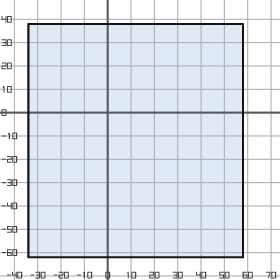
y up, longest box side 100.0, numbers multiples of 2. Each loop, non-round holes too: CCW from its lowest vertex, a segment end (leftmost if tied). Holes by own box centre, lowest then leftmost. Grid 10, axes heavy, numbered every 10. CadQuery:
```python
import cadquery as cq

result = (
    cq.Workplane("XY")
    .moveTo(-34.0, -62.0)
    .lineTo(58.0, -62.0)
    .lineTo(58.0, 38.0)
    .lineTo(-34.0, 38.0)
    .close()
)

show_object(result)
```